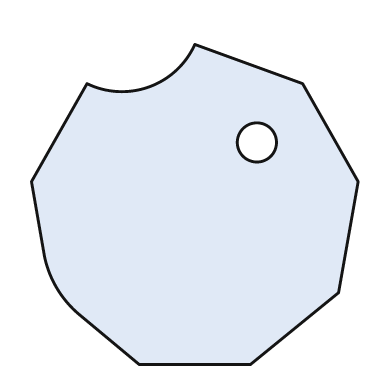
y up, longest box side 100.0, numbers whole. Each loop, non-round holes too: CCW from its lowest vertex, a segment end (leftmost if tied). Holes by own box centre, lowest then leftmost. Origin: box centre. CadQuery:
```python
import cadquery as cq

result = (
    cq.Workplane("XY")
    .moveTo(-17.0, -49.0)
    .lineTo(17.0, -49.0)
    .lineTo(44.0, -27.0)
    .lineTo(50.0, 7.0)
    .lineTo(33.0, 37.0)
    .lineTo(0.0, 49.0)
    .threePointArc((-14.0, 36.0), (-33.0, 37.0))
    .lineTo(-50.0, 7.0)
    .lineTo(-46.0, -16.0)
    .threePointArc((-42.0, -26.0), (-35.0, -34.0))
    .close()
    .moveTo(19.0, 19.0)
    .circle(6.0)
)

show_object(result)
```